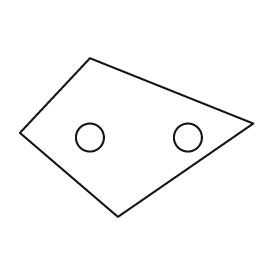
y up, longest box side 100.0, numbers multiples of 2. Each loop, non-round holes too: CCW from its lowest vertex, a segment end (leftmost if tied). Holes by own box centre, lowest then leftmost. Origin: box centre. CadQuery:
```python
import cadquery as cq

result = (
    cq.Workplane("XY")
    .moveTo(-8.0, -34.0)
    .lineTo(50.0, 6.0)
    .lineTo(-20.0, 34.0)
    .lineTo(-50.0, 2.0)
    .close()
    .moveTo(-20.0, 0.0)
    .circle(6.0)
    .moveTo(22.0, 0.0)
    .circle(6.0)
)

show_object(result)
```